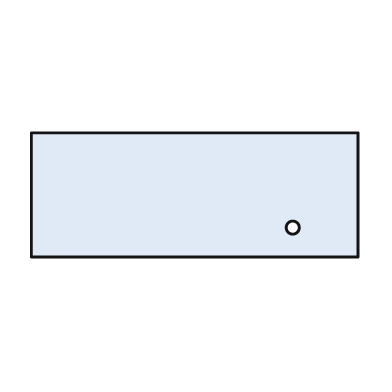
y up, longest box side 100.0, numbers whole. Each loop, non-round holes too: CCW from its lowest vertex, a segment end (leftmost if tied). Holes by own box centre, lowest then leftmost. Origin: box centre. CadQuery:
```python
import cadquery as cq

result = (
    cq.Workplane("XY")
    .moveTo(-50.0, -19.0)
    .lineTo(50.0, -19.0)
    .lineTo(50.0, 19.0)
    .lineTo(-50.0, 19.0)
    .close()
    .moveTo(30.0, -10.0)
    .circle(2.0)
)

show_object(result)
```